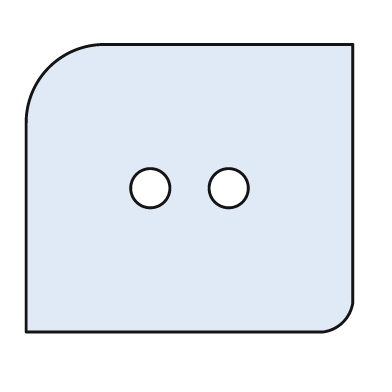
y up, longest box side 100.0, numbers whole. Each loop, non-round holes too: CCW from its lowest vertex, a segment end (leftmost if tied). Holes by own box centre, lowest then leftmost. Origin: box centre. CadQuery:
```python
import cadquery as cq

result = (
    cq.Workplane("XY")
    .moveTo(-50.0, -44.0)
    .lineTo(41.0, -44.0)
    .threePointArc((47.0, -41.0), (50.0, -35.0))
    .lineTo(50.0, 44.0)
    .lineTo(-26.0, 44.0)
    .threePointArc((-43.0, 37.0), (-50.0, 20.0))
    .close()
    .moveTo(-12.0, 0.0)
    .circle(6.0)
    .moveTo(12.0, 0.0)
    .circle(6.0)
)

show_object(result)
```